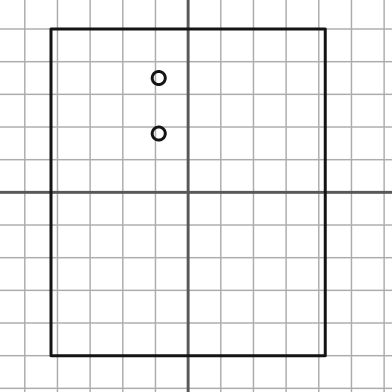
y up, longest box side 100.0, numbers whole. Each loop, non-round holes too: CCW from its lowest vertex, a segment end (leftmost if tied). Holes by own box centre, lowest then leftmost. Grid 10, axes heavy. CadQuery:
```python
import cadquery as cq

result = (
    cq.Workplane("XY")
    .moveTo(-42.0, -50.0)
    .lineTo(42.0, -50.0)
    .lineTo(42.0, 50.0)
    .lineTo(-42.0, 50.0)
    .close()
    .moveTo(-9.0, 18.0)
    .circle(2.0)
    .moveTo(-9.0, 35.0)
    .circle(2.0)
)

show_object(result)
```